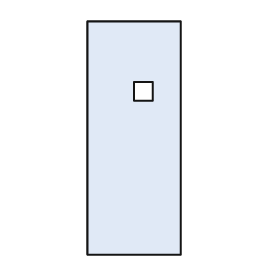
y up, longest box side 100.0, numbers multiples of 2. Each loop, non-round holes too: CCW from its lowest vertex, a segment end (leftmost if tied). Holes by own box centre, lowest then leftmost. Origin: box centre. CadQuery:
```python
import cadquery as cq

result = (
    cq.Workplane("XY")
    .moveTo(-20.0, -50.0)
    .lineTo(20.0, -50.0)
    .lineTo(20.0, 50.0)
    .lineTo(-20.0, 50.0)
    .close()
    .moveTo(0.0, 16.0)
    .lineTo(8.0, 16.0)
    .lineTo(8.0, 24.0)
    .lineTo(0.0, 24.0)
    .close()
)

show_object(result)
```